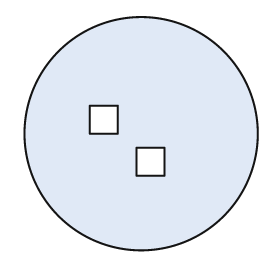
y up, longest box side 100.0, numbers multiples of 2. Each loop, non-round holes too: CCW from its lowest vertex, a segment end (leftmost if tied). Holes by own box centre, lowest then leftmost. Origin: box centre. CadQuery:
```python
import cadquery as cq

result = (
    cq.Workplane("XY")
    .moveTo(0.0, 0.0)
    .circle(50.0)
    .moveTo(-2.0, -18.0)
    .lineTo(10.0, -18.0)
    .lineTo(10.0, -6.0)
    .lineTo(-2.0, -6.0)
    .close()
    .moveTo(-22.0, 0.0)
    .lineTo(-10.0, 0.0)
    .lineTo(-10.0, 12.0)
    .lineTo(-22.0, 12.0)
    .close()
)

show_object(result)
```